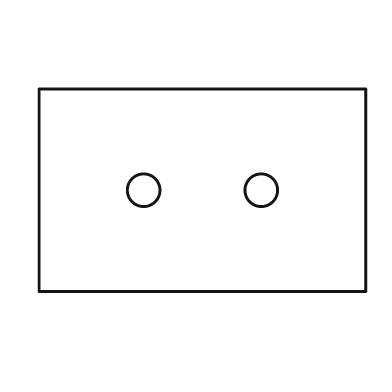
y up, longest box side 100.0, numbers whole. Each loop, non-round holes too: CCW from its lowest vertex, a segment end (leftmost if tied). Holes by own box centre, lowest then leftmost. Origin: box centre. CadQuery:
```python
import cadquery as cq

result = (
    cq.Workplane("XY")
    .moveTo(-50.0, -31.0)
    .lineTo(50.0, -31.0)
    .lineTo(50.0, 31.0)
    .lineTo(-50.0, 31.0)
    .close()
    .moveTo(-18.0, 0.0)
    .circle(5.0)
    .moveTo(18.0, 0.0)
    .circle(5.0)
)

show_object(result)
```